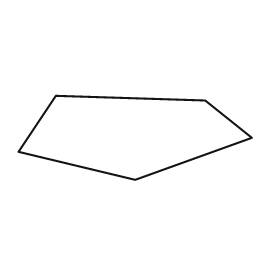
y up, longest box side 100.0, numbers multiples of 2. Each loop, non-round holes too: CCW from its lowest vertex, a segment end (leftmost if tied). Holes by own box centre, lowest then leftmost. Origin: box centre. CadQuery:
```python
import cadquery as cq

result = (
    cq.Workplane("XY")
    .moveTo(0.0, -18.0)
    .lineTo(50.0, 0.0)
    .lineTo(30.0, 16.0)
    .lineTo(-34.0, 18.0)
    .lineTo(-50.0, -6.0)
    .close()
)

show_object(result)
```